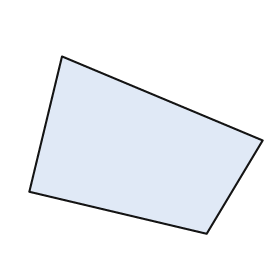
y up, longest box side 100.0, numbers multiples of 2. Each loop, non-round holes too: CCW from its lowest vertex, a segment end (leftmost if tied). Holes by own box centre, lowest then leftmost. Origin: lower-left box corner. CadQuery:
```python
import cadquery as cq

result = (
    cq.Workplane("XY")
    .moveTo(76.0, 0.0)
    .lineTo(100.0, 40.0)
    .lineTo(14.0, 76.0)
    .lineTo(0.0, 18.0)
    .close()
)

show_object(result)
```